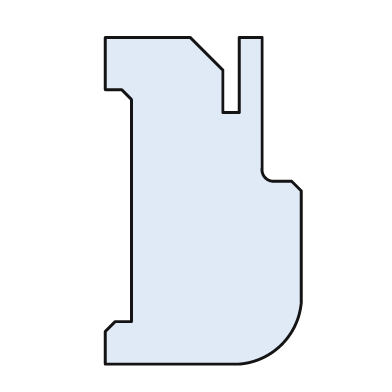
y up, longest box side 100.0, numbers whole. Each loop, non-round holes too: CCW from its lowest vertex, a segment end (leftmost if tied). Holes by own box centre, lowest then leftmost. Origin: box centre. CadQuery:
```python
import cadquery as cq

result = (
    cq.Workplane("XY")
    .moveTo(-30.0, -50.0)
    .lineTo(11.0, -50.0)
    .threePointArc((24.0, -44.0), (30.0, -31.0))
    .lineTo(30.0, 3.0)
    .lineTo(27.0, 6.0)
    .lineTo(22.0, 6.0)
    .threePointArc((19.0, 7.0), (18.0, 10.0))
    .lineTo(18.0, 50.0)
    .lineTo(11.0, 50.0)
    .lineTo(11.0, 27.0)
    .lineTo(6.0, 27.0)
    .lineTo(6.0, 40.0)
    .lineTo(-4.0, 50.0)
    .lineTo(-30.0, 50.0)
    .lineTo(-30.0, 34.0)
    .lineTo(-25.0, 34.0)
    .lineTo(-22.0, 31.0)
    .lineTo(-22.0, -37.0)
    .lineTo(-27.0, -37.0)
    .lineTo(-30.0, -40.0)
    .close()
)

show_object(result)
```